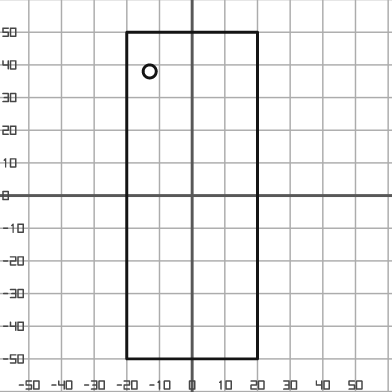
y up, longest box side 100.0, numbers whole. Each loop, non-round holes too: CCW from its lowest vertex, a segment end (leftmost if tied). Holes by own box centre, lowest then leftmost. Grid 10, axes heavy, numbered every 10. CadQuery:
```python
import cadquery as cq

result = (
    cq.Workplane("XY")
    .moveTo(-20.0, -50.0)
    .lineTo(20.0, -50.0)
    .lineTo(20.0, 50.0)
    .lineTo(-20.0, 50.0)
    .close()
    .moveTo(-13.0, 38.0)
    .circle(2.0)
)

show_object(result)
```